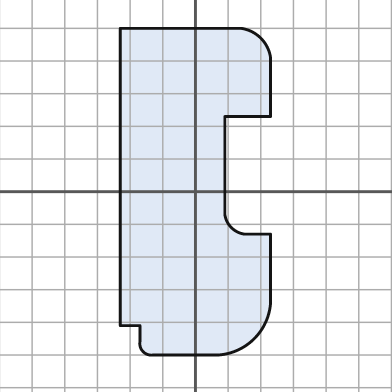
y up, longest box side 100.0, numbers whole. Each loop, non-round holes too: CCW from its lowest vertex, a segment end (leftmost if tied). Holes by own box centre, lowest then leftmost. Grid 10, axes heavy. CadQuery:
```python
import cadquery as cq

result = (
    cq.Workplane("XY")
    .moveTo(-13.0, -50.0)
    .lineTo(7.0, -50.0)
    .threePointArc((18.0, -45.0), (23.0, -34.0))
    .lineTo(23.0, -13.0)
    .lineTo(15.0, -13.0)
    .threePointArc((11.0, -11.0), (9.0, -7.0))
    .lineTo(9.0, 23.0)
    .lineTo(23.0, 23.0)
    .lineTo(23.0, 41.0)
    .threePointArc((20.0, 47.0), (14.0, 50.0))
    .lineTo(-23.0, 50.0)
    .lineTo(-23.0, -41.0)
    .lineTo(-17.0, -41.0)
    .lineTo(-17.0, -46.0)
    .threePointArc((-16.0, -49.0), (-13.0, -50.0))
    .close()
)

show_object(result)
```